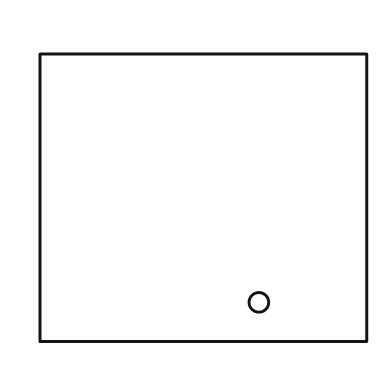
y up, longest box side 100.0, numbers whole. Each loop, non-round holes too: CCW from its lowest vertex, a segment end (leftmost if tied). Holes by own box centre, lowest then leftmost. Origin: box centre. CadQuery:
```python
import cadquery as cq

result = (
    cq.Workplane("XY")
    .moveTo(-50.0, -44.0)
    .lineTo(50.0, -44.0)
    .lineTo(50.0, 44.0)
    .lineTo(-50.0, 44.0)
    .close()
    .moveTo(17.0, -32.0)
    .circle(3.0)
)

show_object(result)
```